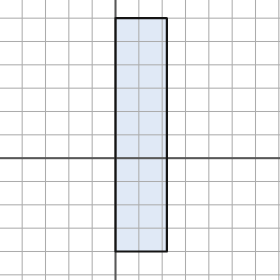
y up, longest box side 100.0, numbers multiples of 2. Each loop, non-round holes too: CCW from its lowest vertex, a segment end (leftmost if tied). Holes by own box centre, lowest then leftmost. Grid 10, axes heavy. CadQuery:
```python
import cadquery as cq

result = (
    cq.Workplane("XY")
    .moveTo(0.0, -40.0)
    .lineTo(22.0, -40.0)
    .lineTo(22.0, 60.0)
    .lineTo(0.0, 60.0)
    .close()
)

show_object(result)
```